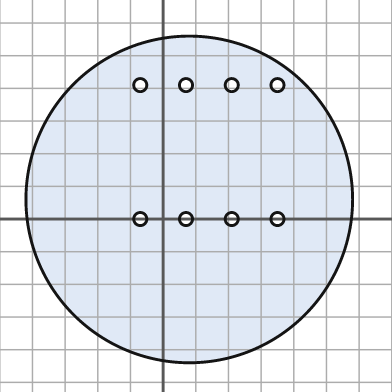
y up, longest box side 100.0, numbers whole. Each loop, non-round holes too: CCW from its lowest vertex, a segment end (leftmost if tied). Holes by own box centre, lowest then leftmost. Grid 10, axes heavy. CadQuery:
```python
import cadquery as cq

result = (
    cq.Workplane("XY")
    .moveTo(8.0, 6.0)
    .circle(50.0)
    .moveTo(-7.0, 0.0)
    .circle(2.0)
    .moveTo(7.0, 0.0)
    .circle(2.0)
    .moveTo(21.0, 0.0)
    .circle(2.0)
    .moveTo(35.0, 0.0)
    .circle(2.0)
    .moveTo(-7.0, 41.0)
    .circle(2.0)
    .moveTo(7.0, 41.0)
    .circle(2.0)
    .moveTo(21.0, 41.0)
    .circle(2.0)
    .moveTo(35.0, 41.0)
    .circle(2.0)
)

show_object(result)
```